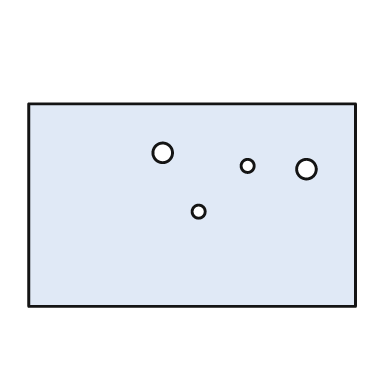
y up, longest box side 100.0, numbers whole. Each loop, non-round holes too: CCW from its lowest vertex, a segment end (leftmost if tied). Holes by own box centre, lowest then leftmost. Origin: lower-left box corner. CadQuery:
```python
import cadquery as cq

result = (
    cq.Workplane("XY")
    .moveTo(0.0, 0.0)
    .lineTo(100.0, 0.0)
    .lineTo(100.0, 62.0)
    .lineTo(0.0, 62.0)
    .close()
    .moveTo(52.0, 29.0)
    .circle(2.0)
    .moveTo(85.0, 42.0)
    .circle(3.0)
    .moveTo(67.0, 43.0)
    .circle(2.0)
    .moveTo(41.0, 47.0)
    .circle(3.0)
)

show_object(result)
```